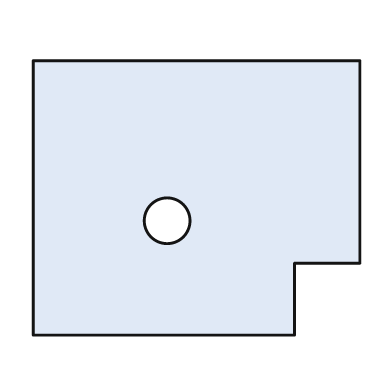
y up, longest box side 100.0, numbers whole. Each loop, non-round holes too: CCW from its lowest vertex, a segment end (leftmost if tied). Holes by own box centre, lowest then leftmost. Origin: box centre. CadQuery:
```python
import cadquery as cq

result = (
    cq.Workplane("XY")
    .moveTo(-50.0, -42.0)
    .lineTo(30.0, -42.0)
    .lineTo(30.0, -20.0)
    .lineTo(50.0, -20.0)
    .lineTo(50.0, 42.0)
    .lineTo(-50.0, 42.0)
    .close()
    .moveTo(-9.0, -7.0)
    .circle(7.0)
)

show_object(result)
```